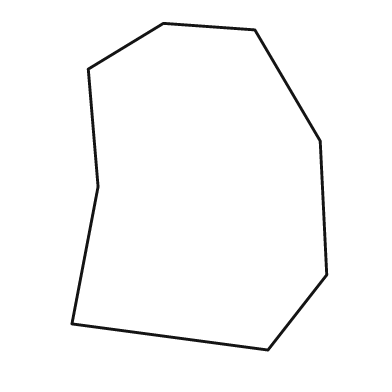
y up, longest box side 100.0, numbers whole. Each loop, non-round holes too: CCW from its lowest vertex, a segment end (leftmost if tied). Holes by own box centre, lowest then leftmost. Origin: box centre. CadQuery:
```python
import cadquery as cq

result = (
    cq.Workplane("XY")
    .moveTo(21.0, -50.0)
    .lineTo(39.0, -27.0)
    .lineTo(37.0, 14.0)
    .lineTo(17.0, 48.0)
    .lineTo(-11.0, 50.0)
    .lineTo(-34.0, 36.0)
    .lineTo(-31.0, 0.0)
    .lineTo(-39.0, -42.0)
    .close()
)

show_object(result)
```